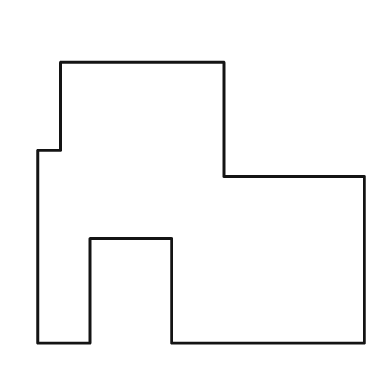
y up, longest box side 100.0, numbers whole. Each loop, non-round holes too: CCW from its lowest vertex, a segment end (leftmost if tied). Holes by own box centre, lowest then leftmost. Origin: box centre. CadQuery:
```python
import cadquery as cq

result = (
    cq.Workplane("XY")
    .moveTo(-50.0, -43.0)
    .lineTo(-34.0, -43.0)
    .lineTo(-34.0, -11.0)
    .lineTo(-9.0, -11.0)
    .lineTo(-9.0, -43.0)
    .lineTo(50.0, -43.0)
    .lineTo(50.0, 8.0)
    .lineTo(7.0, 8.0)
    .lineTo(7.0, 43.0)
    .lineTo(-43.0, 43.0)
    .lineTo(-43.0, 16.0)
    .lineTo(-50.0, 16.0)
    .close()
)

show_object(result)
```